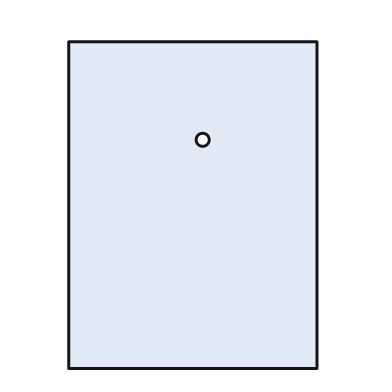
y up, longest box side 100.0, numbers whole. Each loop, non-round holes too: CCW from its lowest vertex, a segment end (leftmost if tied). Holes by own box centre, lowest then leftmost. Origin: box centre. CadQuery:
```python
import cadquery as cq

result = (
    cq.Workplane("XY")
    .moveTo(-38.0, -50.0)
    .lineTo(38.0, -50.0)
    .lineTo(38.0, 50.0)
    .lineTo(-38.0, 50.0)
    .close()
    .moveTo(3.0, 20.0)
    .circle(2.0)
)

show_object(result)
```